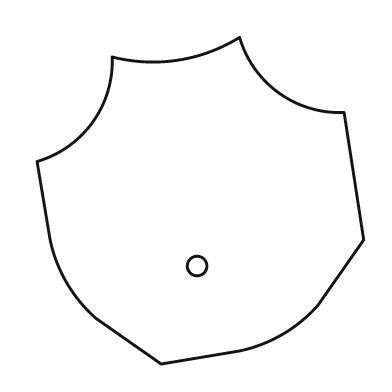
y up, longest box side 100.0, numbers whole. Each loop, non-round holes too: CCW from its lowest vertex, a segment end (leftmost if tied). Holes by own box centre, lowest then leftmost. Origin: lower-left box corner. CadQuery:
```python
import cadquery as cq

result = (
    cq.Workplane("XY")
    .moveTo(38.0, 0.0)
    .lineTo(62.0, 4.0)
    .threePointArc((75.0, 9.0), (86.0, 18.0))
    .lineTo(100.0, 38.0)
    .lineTo(94.0, 77.0)
    .threePointArc((74.0, 83.0), (62.0, 100.0))
    .threePointArc((43.0, 93.0), (23.0, 94.0))
    .threePointArc((17.0, 74.0), (0.0, 62.0))
    .lineTo(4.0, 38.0)
    .threePointArc((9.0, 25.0), (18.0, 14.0))
    .close()
    .moveTo(49.0, 30.0)
    .circle(3.0)
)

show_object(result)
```